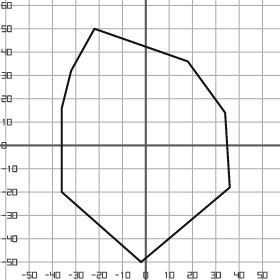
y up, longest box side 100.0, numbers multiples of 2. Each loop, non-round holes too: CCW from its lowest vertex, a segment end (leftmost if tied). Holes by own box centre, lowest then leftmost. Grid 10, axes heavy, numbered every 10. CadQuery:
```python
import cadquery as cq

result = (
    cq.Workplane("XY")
    .moveTo(-2.0, -50.0)
    .lineTo(36.0, -18.0)
    .lineTo(34.0, 14.0)
    .lineTo(18.0, 36.0)
    .lineTo(-22.0, 50.0)
    .lineTo(-32.0, 32.0)
    .lineTo(-36.0, 16.0)
    .lineTo(-36.0, -20.0)
    .close()
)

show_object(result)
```